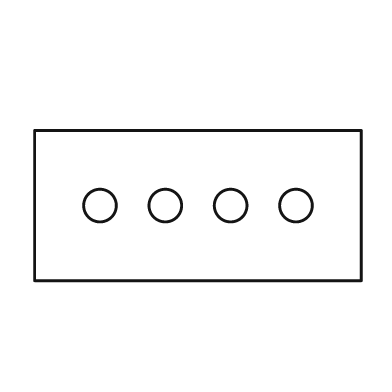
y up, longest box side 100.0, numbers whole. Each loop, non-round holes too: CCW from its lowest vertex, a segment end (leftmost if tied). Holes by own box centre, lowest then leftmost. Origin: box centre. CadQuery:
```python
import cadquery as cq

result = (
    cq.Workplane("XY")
    .moveTo(-50.0, -23.0)
    .lineTo(50.0, -23.0)
    .lineTo(50.0, 23.0)
    .lineTo(-50.0, 23.0)
    .close()
    .moveTo(-30.0, 0.0)
    .circle(5.0)
    .moveTo(-10.0, 0.0)
    .circle(5.0)
    .moveTo(10.0, 0.0)
    .circle(5.0)
    .moveTo(30.0, 0.0)
    .circle(5.0)
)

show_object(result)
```